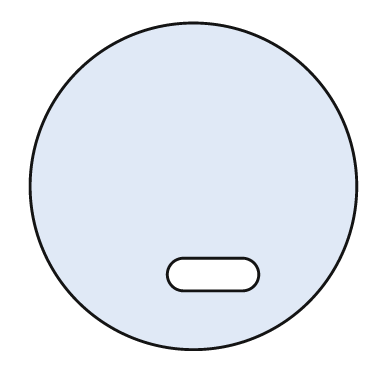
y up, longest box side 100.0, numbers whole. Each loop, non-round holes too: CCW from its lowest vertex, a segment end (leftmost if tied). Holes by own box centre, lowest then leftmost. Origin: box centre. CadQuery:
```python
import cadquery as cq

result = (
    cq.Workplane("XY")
    .moveTo(0.0, 0.0)
    .circle(50.0)
    .moveTo(-3.0, -32.0)
    .lineTo(15.0, -32.0)
    .threePointArc((20.0, -27.0), (15.0, -22.0))
    .lineTo(-3.0, -22.0)
    .threePointArc((-8.0, -27.0), (-3.0, -32.0))
    .close()
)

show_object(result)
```